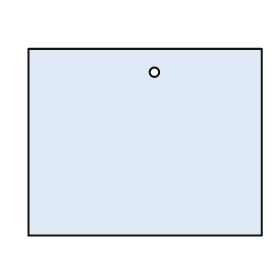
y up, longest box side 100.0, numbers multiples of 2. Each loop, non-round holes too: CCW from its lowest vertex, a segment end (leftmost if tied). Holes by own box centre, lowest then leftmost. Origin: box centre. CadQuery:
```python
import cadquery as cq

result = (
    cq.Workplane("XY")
    .moveTo(-50.0, -40.0)
    .lineTo(50.0, -40.0)
    .lineTo(50.0, 40.0)
    .lineTo(-50.0, 40.0)
    .close()
    .moveTo(4.0, 30.0)
    .circle(2.0)
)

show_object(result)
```